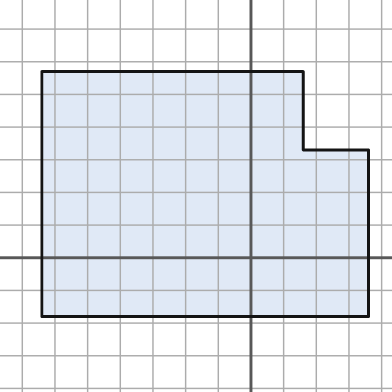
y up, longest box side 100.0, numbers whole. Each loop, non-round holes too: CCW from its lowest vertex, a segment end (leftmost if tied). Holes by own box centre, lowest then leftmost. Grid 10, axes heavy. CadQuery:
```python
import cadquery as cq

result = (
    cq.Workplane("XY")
    .moveTo(-64.0, -18.0)
    .lineTo(36.0, -18.0)
    .lineTo(36.0, 33.0)
    .lineTo(16.0, 33.0)
    .lineTo(16.0, 57.0)
    .lineTo(-64.0, 57.0)
    .close()
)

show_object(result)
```